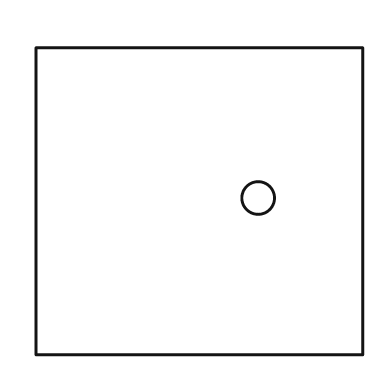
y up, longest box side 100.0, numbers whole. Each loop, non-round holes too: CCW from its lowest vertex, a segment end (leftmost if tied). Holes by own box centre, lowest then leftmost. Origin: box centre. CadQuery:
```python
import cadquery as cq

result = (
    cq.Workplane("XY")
    .moveTo(-50.0, -47.0)
    .lineTo(50.0, -47.0)
    .lineTo(50.0, 47.0)
    .lineTo(-50.0, 47.0)
    .close()
    .moveTo(18.0, 1.0)
    .circle(5.0)
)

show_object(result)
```